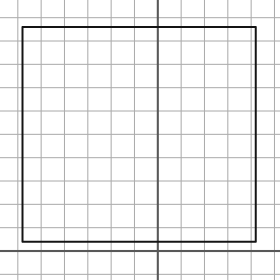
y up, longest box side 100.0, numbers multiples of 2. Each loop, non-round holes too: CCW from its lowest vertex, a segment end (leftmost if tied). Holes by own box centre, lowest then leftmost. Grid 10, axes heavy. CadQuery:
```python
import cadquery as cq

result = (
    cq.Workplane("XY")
    .moveTo(-58.0, 4.0)
    .lineTo(42.0, 4.0)
    .lineTo(42.0, 96.0)
    .lineTo(-58.0, 96.0)
    .close()
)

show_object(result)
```